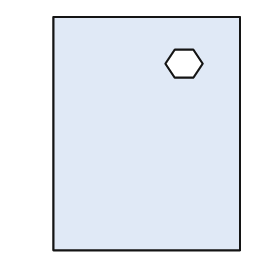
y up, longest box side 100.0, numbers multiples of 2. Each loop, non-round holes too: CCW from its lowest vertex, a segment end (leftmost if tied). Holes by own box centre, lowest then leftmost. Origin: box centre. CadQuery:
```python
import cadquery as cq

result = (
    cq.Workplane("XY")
    .moveTo(-40.0, -50.0)
    .lineTo(40.0, -50.0)
    .lineTo(40.0, 50.0)
    .lineTo(-40.0, 50.0)
    .close()
    .moveTo(12.0, 24.0)
    .lineTo(20.0, 24.0)
    .lineTo(24.0, 30.0)
    .lineTo(20.0, 36.0)
    .lineTo(12.0, 36.0)
    .lineTo(8.0, 30.0)
    .close()
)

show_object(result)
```